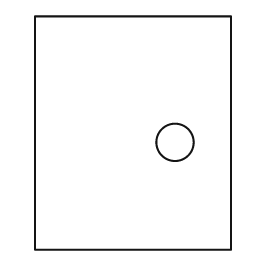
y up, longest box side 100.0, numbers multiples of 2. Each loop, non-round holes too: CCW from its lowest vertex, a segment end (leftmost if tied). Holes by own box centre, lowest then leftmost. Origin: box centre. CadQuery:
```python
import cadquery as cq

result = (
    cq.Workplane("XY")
    .moveTo(-42.0, -50.0)
    .lineTo(42.0, -50.0)
    .lineTo(42.0, 50.0)
    .lineTo(-42.0, 50.0)
    .close()
    .moveTo(18.0, -4.0)
    .circle(8.0)
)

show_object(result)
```